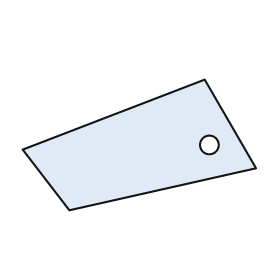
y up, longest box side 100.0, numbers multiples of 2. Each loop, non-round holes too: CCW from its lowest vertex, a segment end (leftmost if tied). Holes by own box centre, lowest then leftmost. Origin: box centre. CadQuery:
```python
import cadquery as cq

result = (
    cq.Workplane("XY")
    .moveTo(-30.0, -28.0)
    .lineTo(50.0, -10.0)
    .lineTo(28.0, 28.0)
    .lineTo(-50.0, -2.0)
    .close()
    .moveTo(30.0, 0.0)
    .circle(4.0)
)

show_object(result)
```